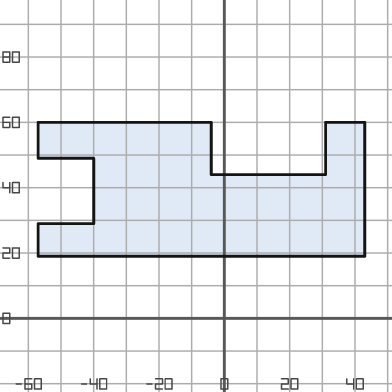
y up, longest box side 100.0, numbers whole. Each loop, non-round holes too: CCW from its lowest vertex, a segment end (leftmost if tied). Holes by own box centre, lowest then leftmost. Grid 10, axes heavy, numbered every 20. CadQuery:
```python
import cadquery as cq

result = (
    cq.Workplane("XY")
    .moveTo(-57.0, 19.0)
    .lineTo(43.0, 19.0)
    .lineTo(43.0, 60.0)
    .lineTo(31.0, 60.0)
    .lineTo(31.0, 44.0)
    .lineTo(-4.0, 44.0)
    .lineTo(-4.0, 60.0)
    .lineTo(-57.0, 60.0)
    .lineTo(-57.0, 49.0)
    .lineTo(-40.0, 49.0)
    .lineTo(-40.0, 29.0)
    .lineTo(-57.0, 29.0)
    .close()
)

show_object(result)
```